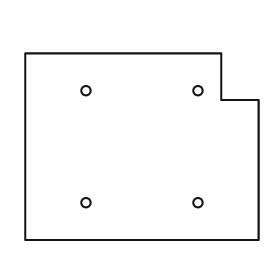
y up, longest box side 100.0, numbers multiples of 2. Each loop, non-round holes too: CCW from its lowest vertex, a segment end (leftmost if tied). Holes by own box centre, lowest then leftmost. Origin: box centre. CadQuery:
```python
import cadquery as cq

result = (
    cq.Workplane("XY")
    .moveTo(-50.0, -40.0)
    .lineTo(50.0, -40.0)
    .lineTo(50.0, 20.0)
    .lineTo(34.0, 20.0)
    .lineTo(34.0, 40.0)
    .lineTo(-50.0, 40.0)
    .close()
    .moveTo(-24.0, -24.0)
    .circle(2.0)
    .moveTo(24.0, -24.0)
    .circle(2.0)
    .moveTo(-24.0, 24.0)
    .circle(2.0)
    .moveTo(24.0, 24.0)
    .circle(2.0)
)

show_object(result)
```